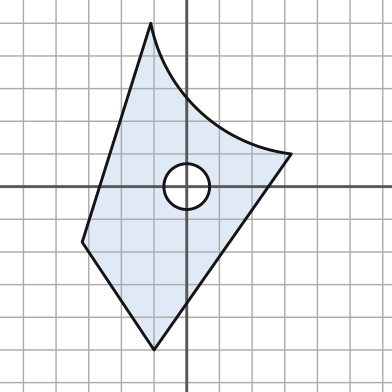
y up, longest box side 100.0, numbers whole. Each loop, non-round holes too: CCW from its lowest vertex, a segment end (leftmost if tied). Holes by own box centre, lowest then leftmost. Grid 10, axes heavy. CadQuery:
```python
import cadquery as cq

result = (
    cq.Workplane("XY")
    .moveTo(-10.0, -50.0)
    .lineTo(32.0, 10.0)
    .threePointArc((4.0, 23.0), (-11.0, 50.0))
    .lineTo(-32.0, -17.0)
    .close()
    .moveTo(0.0, 0.0)
    .circle(7.0)
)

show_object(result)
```